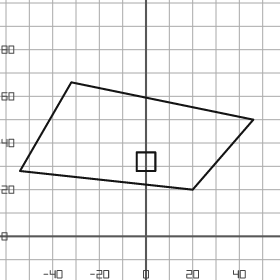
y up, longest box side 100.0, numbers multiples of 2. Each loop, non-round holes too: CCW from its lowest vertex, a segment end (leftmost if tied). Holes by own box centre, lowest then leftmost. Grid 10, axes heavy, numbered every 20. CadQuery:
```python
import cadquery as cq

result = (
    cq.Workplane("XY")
    .moveTo(20.0, 20.0)
    .lineTo(46.0, 50.0)
    .lineTo(-32.0, 66.0)
    .lineTo(-54.0, 28.0)
    .close()
    .moveTo(-4.0, 28.0)
    .lineTo(4.0, 28.0)
    .lineTo(4.0, 36.0)
    .lineTo(-4.0, 36.0)
    .close()
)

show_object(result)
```